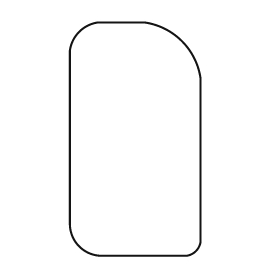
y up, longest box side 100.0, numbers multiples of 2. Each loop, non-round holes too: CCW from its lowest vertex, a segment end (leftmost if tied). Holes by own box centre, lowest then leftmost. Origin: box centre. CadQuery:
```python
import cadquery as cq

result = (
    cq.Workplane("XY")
    .moveTo(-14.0, -50.0)
    .lineTo(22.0, -50.0)
    .threePointArc((26.0, -48.0), (28.0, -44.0))
    .lineTo(28.0, 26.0)
    .threePointArc((20.0, 42.0), (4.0, 50.0))
    .lineTo(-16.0, 50.0)
    .threePointArc((-24.0, 46.0), (-28.0, 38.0))
    .lineTo(-28.0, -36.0)
    .threePointArc((-24.0, -46.0), (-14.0, -50.0))
    .close()
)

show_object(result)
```